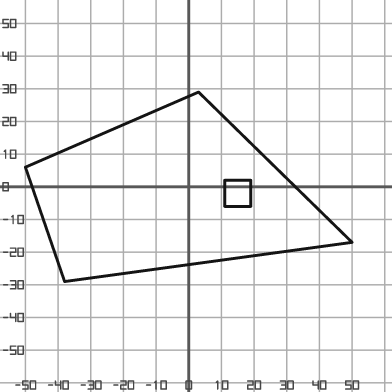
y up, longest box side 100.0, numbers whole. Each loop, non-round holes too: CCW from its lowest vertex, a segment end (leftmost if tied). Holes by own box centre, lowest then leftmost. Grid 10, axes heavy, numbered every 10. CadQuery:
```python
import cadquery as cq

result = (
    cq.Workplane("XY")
    .moveTo(-38.0, -29.0)
    .lineTo(50.0, -17.0)
    .lineTo(3.0, 29.0)
    .lineTo(-50.0, 6.0)
    .close()
    .moveTo(11.0, -6.0)
    .lineTo(19.0, -6.0)
    .lineTo(19.0, 2.0)
    .lineTo(11.0, 2.0)
    .close()
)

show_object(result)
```